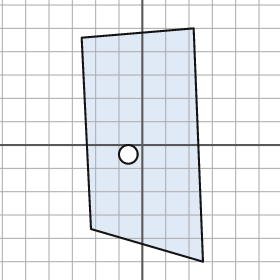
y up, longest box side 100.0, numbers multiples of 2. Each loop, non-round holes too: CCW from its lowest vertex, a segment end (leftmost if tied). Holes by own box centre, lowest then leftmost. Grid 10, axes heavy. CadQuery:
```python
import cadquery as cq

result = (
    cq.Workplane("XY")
    .moveTo(26.0, -50.0)
    .lineTo(22.0, 50.0)
    .lineTo(-26.0, 46.0)
    .lineTo(-22.0, -36.0)
    .close()
    .moveTo(-6.0, -4.0)
    .circle(4.0)
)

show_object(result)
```